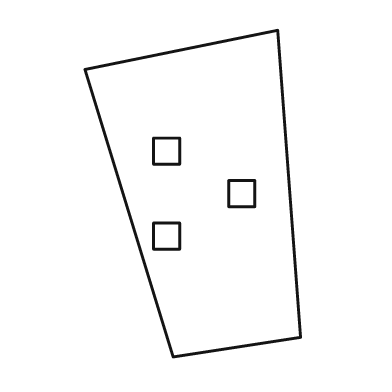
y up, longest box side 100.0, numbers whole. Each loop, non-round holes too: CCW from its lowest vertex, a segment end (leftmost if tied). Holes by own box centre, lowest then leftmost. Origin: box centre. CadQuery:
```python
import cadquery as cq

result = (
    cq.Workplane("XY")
    .moveTo(-6.0, -50.0)
    .lineTo(33.0, -44.0)
    .lineTo(26.0, 50.0)
    .lineTo(-33.0, 38.0)
    .close()
    .moveTo(-12.0, -17.0)
    .lineTo(-4.0, -17.0)
    .lineTo(-4.0, -9.0)
    .lineTo(-12.0, -9.0)
    .close()
    .moveTo(11.0, -4.0)
    .lineTo(19.0, -4.0)
    .lineTo(19.0, 4.0)
    .lineTo(11.0, 4.0)
    .close()
    .moveTo(-12.0, 9.0)
    .lineTo(-4.0, 9.0)
    .lineTo(-4.0, 17.0)
    .lineTo(-12.0, 17.0)
    .close()
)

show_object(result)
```